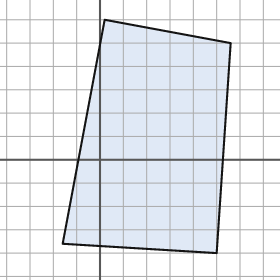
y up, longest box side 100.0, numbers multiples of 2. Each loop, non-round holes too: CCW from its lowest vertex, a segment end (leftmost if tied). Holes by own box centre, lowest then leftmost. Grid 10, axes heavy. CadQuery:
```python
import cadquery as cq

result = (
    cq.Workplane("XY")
    .moveTo(50.0, -40.0)
    .lineTo(56.0, 50.0)
    .lineTo(2.0, 60.0)
    .lineTo(-16.0, -36.0)
    .close()
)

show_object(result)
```